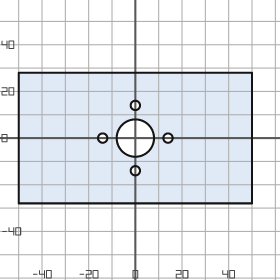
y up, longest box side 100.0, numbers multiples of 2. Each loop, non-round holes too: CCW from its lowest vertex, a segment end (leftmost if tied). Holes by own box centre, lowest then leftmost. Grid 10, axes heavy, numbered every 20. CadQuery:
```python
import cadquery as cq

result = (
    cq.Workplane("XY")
    .moveTo(-50.0, -28.0)
    .lineTo(50.0, -28.0)
    .lineTo(50.0, 28.0)
    .lineTo(-50.0, 28.0)
    .close()
    .moveTo(0.0, -14.0)
    .circle(2.0)
    .moveTo(-14.0, 0.0)
    .circle(2.0)
    .moveTo(0.0, 0.0)
    .circle(8.0)
    .moveTo(14.0, 0.0)
    .circle(2.0)
    .moveTo(0.0, 14.0)
    .circle(2.0)
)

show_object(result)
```